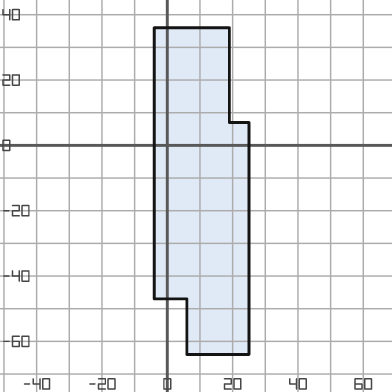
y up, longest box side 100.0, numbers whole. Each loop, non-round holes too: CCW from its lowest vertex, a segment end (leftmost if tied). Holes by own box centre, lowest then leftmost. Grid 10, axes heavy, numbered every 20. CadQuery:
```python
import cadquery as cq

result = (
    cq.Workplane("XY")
    .moveTo(6.0, -64.0)
    .lineTo(25.0, -64.0)
    .lineTo(25.0, 7.0)
    .lineTo(19.0, 7.0)
    .lineTo(19.0, 36.0)
    .lineTo(-4.0, 36.0)
    .lineTo(-4.0, -47.0)
    .lineTo(6.0, -47.0)
    .close()
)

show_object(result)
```